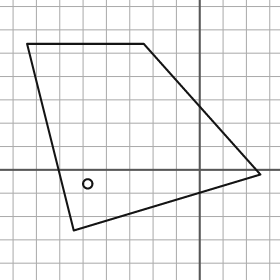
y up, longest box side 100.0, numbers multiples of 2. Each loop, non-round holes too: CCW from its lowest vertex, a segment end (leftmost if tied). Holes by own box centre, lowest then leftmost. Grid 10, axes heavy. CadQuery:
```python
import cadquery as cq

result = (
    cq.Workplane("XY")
    .moveTo(-54.0, -26.0)
    .lineTo(26.0, -2.0)
    .lineTo(-24.0, 54.0)
    .lineTo(-74.0, 54.0)
    .close()
    .moveTo(-48.0, -6.0)
    .circle(2.0)
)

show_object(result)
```